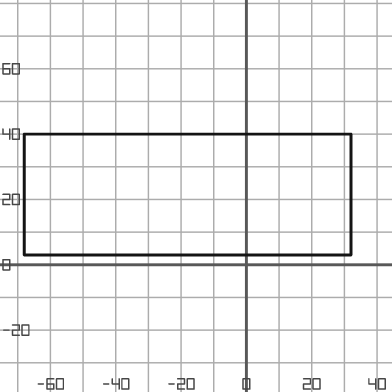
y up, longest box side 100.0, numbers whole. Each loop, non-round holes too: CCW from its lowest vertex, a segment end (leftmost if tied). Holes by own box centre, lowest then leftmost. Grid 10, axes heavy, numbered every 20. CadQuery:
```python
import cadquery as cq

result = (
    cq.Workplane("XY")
    .moveTo(-68.0, 3.0)
    .lineTo(32.0, 3.0)
    .lineTo(32.0, 40.0)
    .lineTo(-68.0, 40.0)
    .close()
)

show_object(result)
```